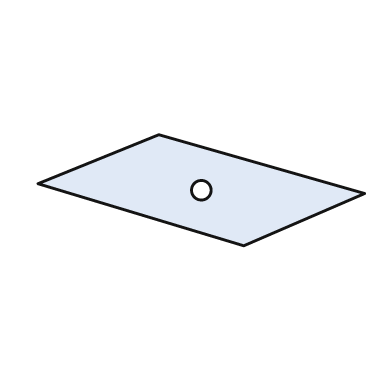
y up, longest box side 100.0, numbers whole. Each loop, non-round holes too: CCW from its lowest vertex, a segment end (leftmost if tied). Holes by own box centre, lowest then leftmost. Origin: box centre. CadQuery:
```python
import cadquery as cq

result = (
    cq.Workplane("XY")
    .moveTo(13.0, -17.0)
    .lineTo(50.0, -1.0)
    .lineTo(-13.0, 17.0)
    .lineTo(-50.0, 2.0)
    .close()
    .moveTo(0.0, 0.0)
    .circle(3.0)
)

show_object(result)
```